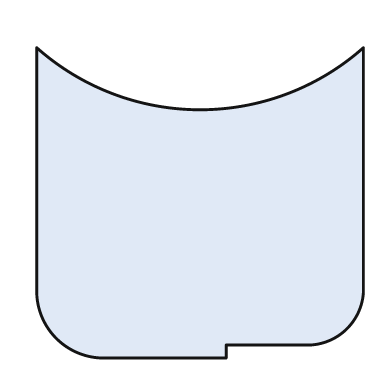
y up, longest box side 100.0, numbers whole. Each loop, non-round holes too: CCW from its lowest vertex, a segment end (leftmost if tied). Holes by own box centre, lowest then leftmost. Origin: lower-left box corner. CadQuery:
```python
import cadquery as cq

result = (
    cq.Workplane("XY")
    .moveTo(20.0, 0.0)
    .lineTo(58.0, 0.0)
    .lineTo(58.0, 4.0)
    .lineTo(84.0, 4.0)
    .threePointArc((95.0, 9.0), (100.0, 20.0))
    .lineTo(100.0, 95.0)
    .threePointArc((50.0, 76.0), (0.0, 95.0))
    .lineTo(0.0, 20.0)
    .threePointArc((6.0, 6.0), (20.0, 0.0))
    .close()
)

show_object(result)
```